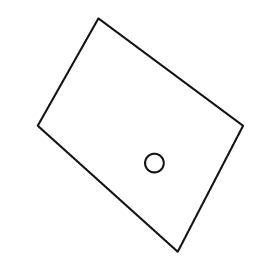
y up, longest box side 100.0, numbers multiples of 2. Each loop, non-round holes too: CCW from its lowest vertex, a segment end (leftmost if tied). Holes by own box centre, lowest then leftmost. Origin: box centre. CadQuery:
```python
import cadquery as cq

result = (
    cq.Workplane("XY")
    .moveTo(16.0, -50.0)
    .lineTo(44.0, 4.0)
    .lineTo(-18.0, 50.0)
    .lineTo(-44.0, 4.0)
    .close()
    .moveTo(6.0, -12.0)
    .circle(4.0)
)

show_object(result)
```